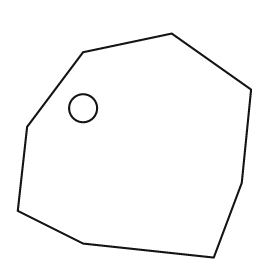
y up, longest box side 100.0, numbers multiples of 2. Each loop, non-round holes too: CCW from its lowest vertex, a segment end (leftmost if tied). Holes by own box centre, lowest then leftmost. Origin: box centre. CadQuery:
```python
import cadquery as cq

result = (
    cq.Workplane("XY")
    .moveTo(34.0, -48.0)
    .lineTo(46.0, -16.0)
    .lineTo(50.0, 24.0)
    .lineTo(16.0, 48.0)
    .lineTo(-22.0, 40.0)
    .lineTo(-46.0, 8.0)
    .lineTo(-50.0, -28.0)
    .lineTo(-22.0, -42.0)
    .close()
    .moveTo(-22.0, 16.0)
    .circle(6.0)
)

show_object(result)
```